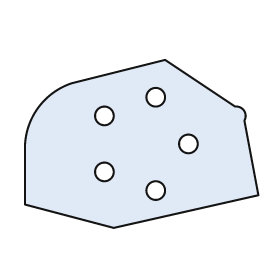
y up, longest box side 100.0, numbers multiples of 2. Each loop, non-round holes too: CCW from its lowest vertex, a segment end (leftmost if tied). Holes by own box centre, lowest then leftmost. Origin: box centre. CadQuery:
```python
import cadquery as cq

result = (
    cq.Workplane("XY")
    .moveTo(-12.0, -36.0)
    .lineTo(50.0, -22.0)
    .lineTo(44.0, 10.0)
    .threePointArc((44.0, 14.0), (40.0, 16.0))
    .lineTo(10.0, 36.0)
    .lineTo(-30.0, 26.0)
    .threePointArc((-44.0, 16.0), (-50.0, 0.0))
    .lineTo(-50.0, -26.0)
    .close()
    .moveTo(6.0, -20.0)
    .circle(4.0)
    .moveTo(-16.0, -12.0)
    .circle(4.0)
    .moveTo(20.0, 0.0)
    .circle(4.0)
    .moveTo(-16.0, 12.0)
    .circle(4.0)
    .moveTo(6.0, 20.0)
    .circle(4.0)
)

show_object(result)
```